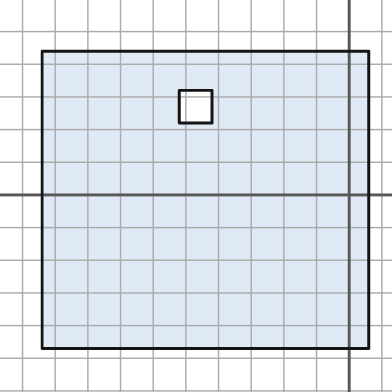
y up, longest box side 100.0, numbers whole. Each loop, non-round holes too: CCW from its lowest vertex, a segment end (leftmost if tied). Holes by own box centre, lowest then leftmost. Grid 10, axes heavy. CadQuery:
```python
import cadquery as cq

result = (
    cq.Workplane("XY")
    .moveTo(-94.0, -47.0)
    .lineTo(6.0, -47.0)
    .lineTo(6.0, 44.0)
    .lineTo(-94.0, 44.0)
    .close()
    .moveTo(-52.0, 22.0)
    .lineTo(-42.0, 22.0)
    .lineTo(-42.0, 32.0)
    .lineTo(-52.0, 32.0)
    .close()
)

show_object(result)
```